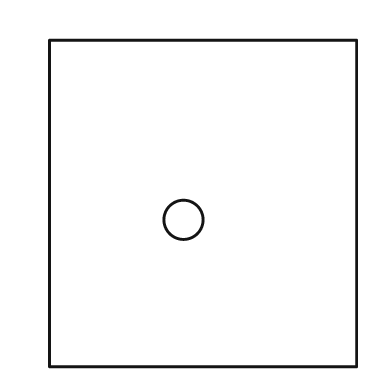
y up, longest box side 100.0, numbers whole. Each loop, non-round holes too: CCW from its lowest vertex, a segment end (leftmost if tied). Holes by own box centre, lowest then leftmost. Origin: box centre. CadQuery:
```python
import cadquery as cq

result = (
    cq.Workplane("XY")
    .moveTo(-47.0, -50.0)
    .lineTo(47.0, -50.0)
    .lineTo(47.0, 50.0)
    .lineTo(-47.0, 50.0)
    .close()
    .moveTo(-6.0, -5.0)
    .circle(6.0)
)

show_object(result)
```